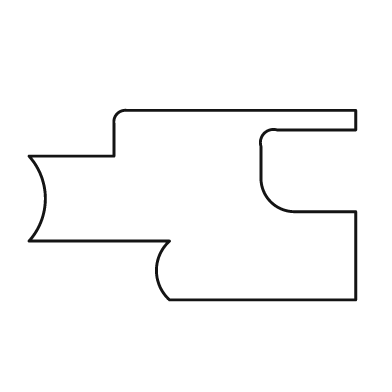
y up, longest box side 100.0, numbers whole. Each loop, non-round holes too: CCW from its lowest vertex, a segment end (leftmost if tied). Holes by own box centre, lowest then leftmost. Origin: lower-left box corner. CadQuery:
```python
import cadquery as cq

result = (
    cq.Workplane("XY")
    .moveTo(43.0, 0.0)
    .lineTo(100.0, 0.0)
    .lineTo(100.0, 27.0)
    .lineTo(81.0, 27.0)
    .threePointArc((74.0, 30.0), (71.0, 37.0))
    .lineTo(71.0, 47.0)
    .threePointArc((72.0, 51.0), (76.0, 52.0))
    .lineTo(100.0, 52.0)
    .lineTo(100.0, 58.0)
    .lineTo(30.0, 58.0)
    .threePointArc((27.0, 57.0), (26.0, 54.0))
    .lineTo(26.0, 44.0)
    .lineTo(0.0, 44.0)
    .threePointArc((5.0, 31.0), (0.0, 18.0))
    .lineTo(43.0, 18.0)
    .threePointArc((39.0, 9.0), (43.0, 0.0))
    .close()
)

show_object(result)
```